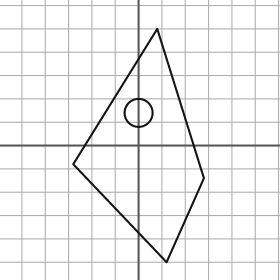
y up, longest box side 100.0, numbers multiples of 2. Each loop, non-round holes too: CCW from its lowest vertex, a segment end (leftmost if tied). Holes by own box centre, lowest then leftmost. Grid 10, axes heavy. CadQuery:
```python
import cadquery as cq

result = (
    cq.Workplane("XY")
    .moveTo(12.0, -50.0)
    .lineTo(28.0, -14.0)
    .lineTo(8.0, 50.0)
    .lineTo(-28.0, -8.0)
    .close()
    .moveTo(0.0, 14.0)
    .circle(6.0)
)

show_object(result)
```